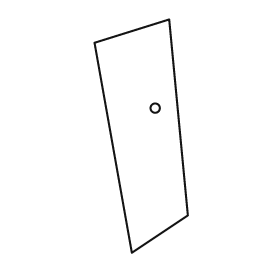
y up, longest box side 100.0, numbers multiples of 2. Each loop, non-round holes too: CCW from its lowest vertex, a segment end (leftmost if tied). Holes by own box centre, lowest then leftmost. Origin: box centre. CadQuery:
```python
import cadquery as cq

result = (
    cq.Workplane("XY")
    .moveTo(-4.0, -50.0)
    .lineTo(20.0, -34.0)
    .lineTo(12.0, 50.0)
    .lineTo(-20.0, 40.0)
    .close()
    .moveTo(6.0, 12.0)
    .circle(2.0)
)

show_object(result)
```